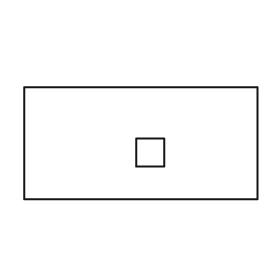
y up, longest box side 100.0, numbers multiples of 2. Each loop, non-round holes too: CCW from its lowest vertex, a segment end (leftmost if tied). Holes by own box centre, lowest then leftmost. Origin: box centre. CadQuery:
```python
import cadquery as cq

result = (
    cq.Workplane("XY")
    .moveTo(-50.0, -24.0)
    .lineTo(50.0, -24.0)
    .lineTo(50.0, 24.0)
    .lineTo(-50.0, 24.0)
    .close()
    .moveTo(-2.0, -10.0)
    .lineTo(10.0, -10.0)
    .lineTo(10.0, 2.0)
    .lineTo(-2.0, 2.0)
    .close()
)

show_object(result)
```